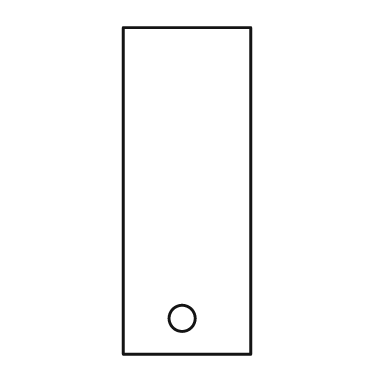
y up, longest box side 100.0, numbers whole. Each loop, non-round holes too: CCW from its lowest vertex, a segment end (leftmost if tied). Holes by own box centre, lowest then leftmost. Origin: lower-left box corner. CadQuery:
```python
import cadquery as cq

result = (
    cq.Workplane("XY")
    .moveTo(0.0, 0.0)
    .lineTo(39.0, 0.0)
    .lineTo(39.0, 100.0)
    .lineTo(0.0, 100.0)
    .close()
    .moveTo(18.0, 11.0)
    .circle(4.0)
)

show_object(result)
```